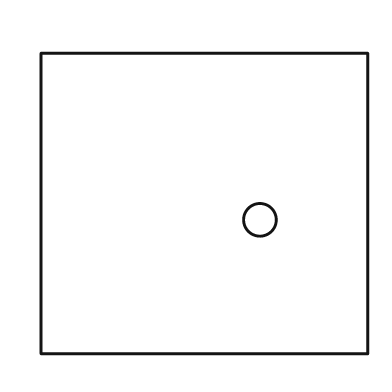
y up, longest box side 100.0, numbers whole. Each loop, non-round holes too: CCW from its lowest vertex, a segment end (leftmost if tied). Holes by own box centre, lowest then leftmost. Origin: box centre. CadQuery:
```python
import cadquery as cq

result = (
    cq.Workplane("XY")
    .moveTo(-50.0, -46.0)
    .lineTo(50.0, -46.0)
    .lineTo(50.0, 46.0)
    .lineTo(-50.0, 46.0)
    .close()
    .moveTo(17.0, -5.0)
    .circle(5.0)
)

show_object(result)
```